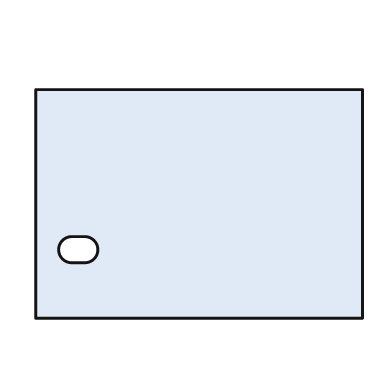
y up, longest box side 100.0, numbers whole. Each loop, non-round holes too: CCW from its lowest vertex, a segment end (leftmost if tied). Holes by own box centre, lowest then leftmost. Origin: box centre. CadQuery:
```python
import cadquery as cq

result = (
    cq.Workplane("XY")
    .moveTo(-50.0, -35.0)
    .lineTo(50.0, -35.0)
    .lineTo(50.0, 35.0)
    .lineTo(-50.0, 35.0)
    .close()
    .moveTo(-39.0, -18.0)
    .lineTo(-35.0, -18.0)
    .threePointArc((-31.0, -14.0), (-35.0, -10.0))
    .lineTo(-39.0, -10.0)
    .threePointArc((-43.0, -14.0), (-39.0, -18.0))
    .close()
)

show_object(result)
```